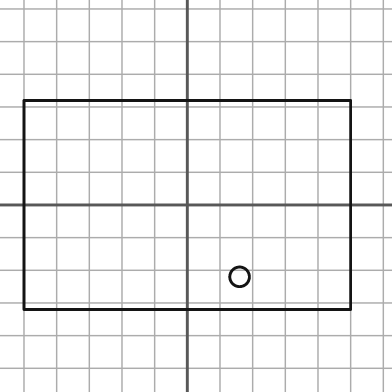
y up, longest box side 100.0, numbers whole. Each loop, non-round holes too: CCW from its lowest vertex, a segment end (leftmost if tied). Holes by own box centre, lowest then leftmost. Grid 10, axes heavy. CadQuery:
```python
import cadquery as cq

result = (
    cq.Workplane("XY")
    .moveTo(-50.0, -32.0)
    .lineTo(50.0, -32.0)
    .lineTo(50.0, 32.0)
    .lineTo(-50.0, 32.0)
    .close()
    .moveTo(16.0, -22.0)
    .circle(3.0)
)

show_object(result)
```